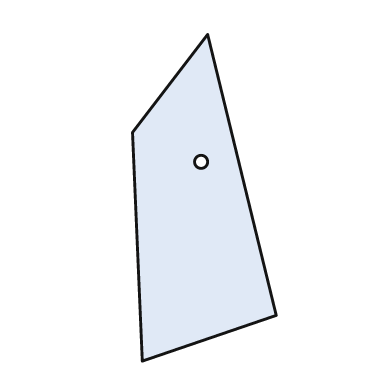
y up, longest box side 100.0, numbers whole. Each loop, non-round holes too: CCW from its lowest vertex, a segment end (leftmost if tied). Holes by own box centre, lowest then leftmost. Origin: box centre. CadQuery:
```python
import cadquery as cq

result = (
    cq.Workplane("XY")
    .moveTo(-19.0, -50.0)
    .lineTo(22.0, -36.0)
    .lineTo(1.0, 50.0)
    .lineTo(-22.0, 20.0)
    .close()
    .moveTo(-1.0, 11.0)
    .circle(2.0)
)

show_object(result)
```